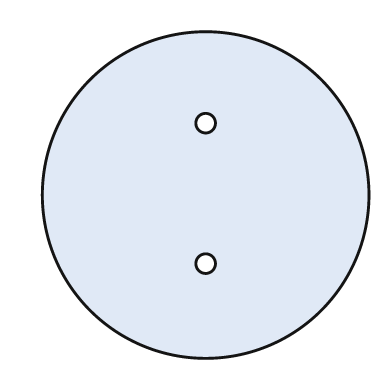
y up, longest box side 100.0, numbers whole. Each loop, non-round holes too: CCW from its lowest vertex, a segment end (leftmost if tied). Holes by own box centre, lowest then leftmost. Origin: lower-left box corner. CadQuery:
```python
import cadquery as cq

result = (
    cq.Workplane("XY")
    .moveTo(50.0, 50.0)
    .circle(50.0)
    .moveTo(50.0, 29.0)
    .circle(3.0)
    .moveTo(50.0, 72.0)
    .circle(3.0)
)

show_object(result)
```